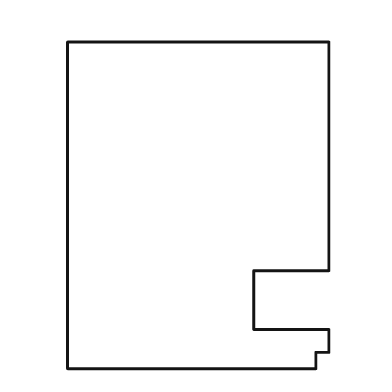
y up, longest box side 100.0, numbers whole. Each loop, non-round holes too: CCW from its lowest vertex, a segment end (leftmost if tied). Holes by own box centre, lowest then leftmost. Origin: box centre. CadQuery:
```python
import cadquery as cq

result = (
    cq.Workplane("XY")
    .moveTo(-40.0, -50.0)
    .lineTo(36.0, -50.0)
    .lineTo(36.0, -45.0)
    .lineTo(40.0, -45.0)
    .lineTo(40.0, -38.0)
    .lineTo(17.0, -38.0)
    .lineTo(17.0, -20.0)
    .lineTo(40.0, -20.0)
    .lineTo(40.0, 50.0)
    .lineTo(-40.0, 50.0)
    .close()
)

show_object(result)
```